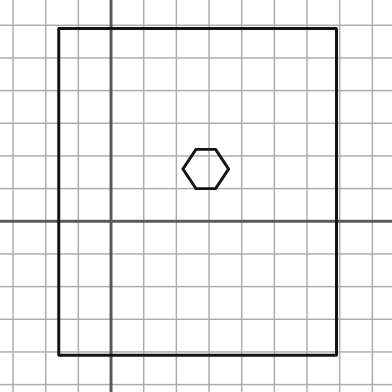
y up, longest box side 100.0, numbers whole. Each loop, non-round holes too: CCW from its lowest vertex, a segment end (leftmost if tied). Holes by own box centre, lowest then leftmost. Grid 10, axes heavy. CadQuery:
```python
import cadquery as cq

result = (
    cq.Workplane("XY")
    .moveTo(-16.0, -41.0)
    .lineTo(69.0, -41.0)
    .lineTo(69.0, 59.0)
    .lineTo(-16.0, 59.0)
    .close()
    .moveTo(26.0, 10.0)
    .lineTo(32.0, 10.0)
    .lineTo(36.0, 16.0)
    .lineTo(32.0, 22.0)
    .lineTo(26.0, 22.0)
    .lineTo(22.0, 16.0)
    .close()
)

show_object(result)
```